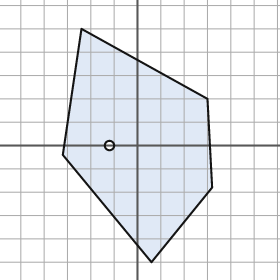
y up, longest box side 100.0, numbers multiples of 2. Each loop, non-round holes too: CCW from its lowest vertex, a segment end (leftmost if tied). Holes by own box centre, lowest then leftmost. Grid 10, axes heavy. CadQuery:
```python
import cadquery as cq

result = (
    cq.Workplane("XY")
    .moveTo(6.0, -50.0)
    .lineTo(32.0, -18.0)
    .lineTo(30.0, 20.0)
    .lineTo(-24.0, 50.0)
    .lineTo(-32.0, -4.0)
    .close()
    .moveTo(-12.0, 0.0)
    .circle(2.0)
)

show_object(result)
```